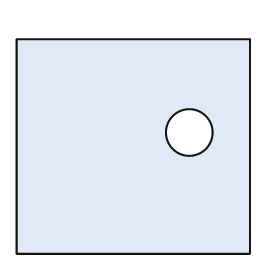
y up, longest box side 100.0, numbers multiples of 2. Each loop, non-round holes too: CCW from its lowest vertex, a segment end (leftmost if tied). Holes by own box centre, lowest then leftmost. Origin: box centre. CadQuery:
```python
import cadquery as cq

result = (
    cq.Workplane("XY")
    .moveTo(-50.0, -46.0)
    .lineTo(50.0, -46.0)
    .lineTo(50.0, 46.0)
    .lineTo(-50.0, 46.0)
    .close()
    .moveTo(24.0, 6.0)
    .circle(10.0)
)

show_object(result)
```